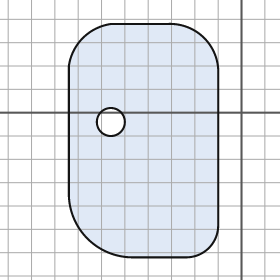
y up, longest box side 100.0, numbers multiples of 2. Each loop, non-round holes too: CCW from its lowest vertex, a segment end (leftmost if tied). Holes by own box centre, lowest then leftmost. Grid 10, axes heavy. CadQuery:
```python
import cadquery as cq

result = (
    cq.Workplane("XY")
    .moveTo(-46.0, -62.0)
    .lineTo(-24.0, -62.0)
    .threePointArc((-14.0, -58.0), (-10.0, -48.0))
    .lineTo(-10.0, 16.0)
    .threePointArc((-16.0, 32.0), (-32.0, 38.0))
    .lineTo(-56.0, 38.0)
    .threePointArc((-68.0, 32.0), (-74.0, 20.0))
    .lineTo(-74.0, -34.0)
    .threePointArc((-66.0, -54.0), (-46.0, -62.0))
    .close()
    .moveTo(-56.0, -4.0)
    .circle(6.0)
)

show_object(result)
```